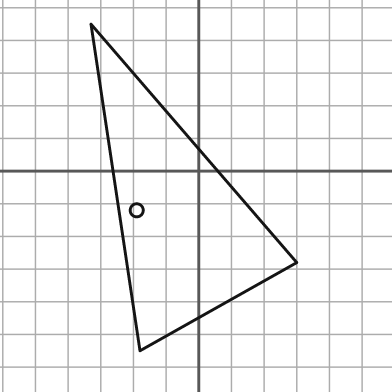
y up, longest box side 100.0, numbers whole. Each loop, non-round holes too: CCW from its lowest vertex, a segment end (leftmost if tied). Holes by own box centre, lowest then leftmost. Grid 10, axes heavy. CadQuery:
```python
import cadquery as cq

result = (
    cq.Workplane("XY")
    .moveTo(-18.0, -55.0)
    .lineTo(30.0, -28.0)
    .lineTo(-33.0, 45.0)
    .close()
    .moveTo(-19.0, -12.0)
    .circle(2.0)
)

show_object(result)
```